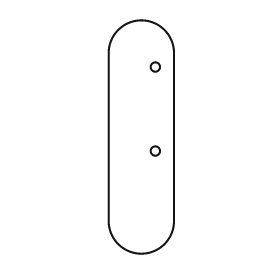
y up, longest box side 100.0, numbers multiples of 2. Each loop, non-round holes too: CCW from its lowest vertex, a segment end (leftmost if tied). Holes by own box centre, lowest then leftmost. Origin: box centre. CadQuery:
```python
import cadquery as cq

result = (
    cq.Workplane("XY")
    .moveTo(-14.0, -36.0)
    .threePointArc((0.0, -50.0), (14.0, -36.0))
    .lineTo(14.0, 36.0)
    .threePointArc((0.0, 50.0), (-14.0, 36.0))
    .close()
    .moveTo(6.0, -6.0)
    .circle(2.0)
    .moveTo(6.0, 30.0)
    .circle(2.0)
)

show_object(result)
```